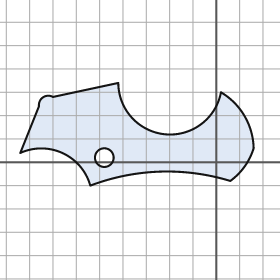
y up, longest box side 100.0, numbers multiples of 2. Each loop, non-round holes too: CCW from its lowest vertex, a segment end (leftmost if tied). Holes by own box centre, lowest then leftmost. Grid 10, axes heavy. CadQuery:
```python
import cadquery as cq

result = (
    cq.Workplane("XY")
    .moveTo(-54.0, -10.0)
    .threePointArc((-24.0, -4.0), (6.0, -8.0))
    .threePointArc((12.0, -2.0), (16.0, 6.0))
    .threePointArc((12.0, 20.0), (2.0, 30.0))
    .threePointArc((-22.0, 12.0), (-42.0, 34.0))
    .lineTo(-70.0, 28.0)
    .threePointArc((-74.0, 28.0), (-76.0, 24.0))
    .lineTo(-84.0, 4.0)
    .threePointArc((-66.0, 4.0), (-54.0, -10.0))
    .close()
    .moveTo(-48.0, 2.0)
    .circle(4.0)
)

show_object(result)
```